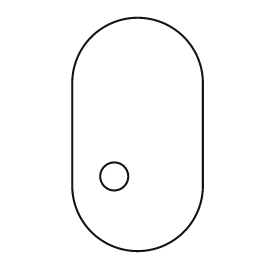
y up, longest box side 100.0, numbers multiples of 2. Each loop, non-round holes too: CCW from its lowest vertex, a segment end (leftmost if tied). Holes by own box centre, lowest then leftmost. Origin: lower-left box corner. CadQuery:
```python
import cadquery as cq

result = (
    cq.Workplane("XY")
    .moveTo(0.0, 28.0)
    .threePointArc((28.0, 0.0), (56.0, 28.0))
    .lineTo(56.0, 72.0)
    .threePointArc((28.0, 100.0), (0.0, 72.0))
    .close()
    .moveTo(18.0, 32.0)
    .circle(6.0)
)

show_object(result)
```